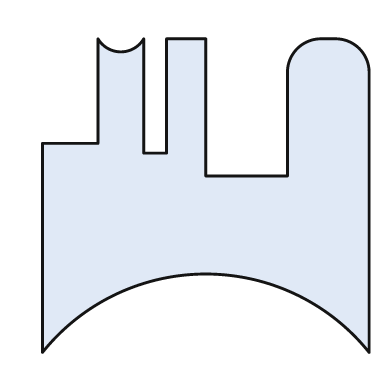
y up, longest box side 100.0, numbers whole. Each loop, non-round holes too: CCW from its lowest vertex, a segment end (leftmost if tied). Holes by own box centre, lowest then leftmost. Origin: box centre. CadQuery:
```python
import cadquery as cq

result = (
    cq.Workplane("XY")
    .moveTo(-50.0, -48.0)
    .threePointArc((0.0, -24.0), (50.0, -48.0))
    .lineTo(50.0, 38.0)
    .threePointArc((47.0, 45.0), (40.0, 48.0))
    .lineTo(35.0, 48.0)
    .threePointArc((28.0, 45.0), (25.0, 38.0))
    .lineTo(25.0, 6.0)
    .lineTo(0.0, 6.0)
    .lineTo(0.0, 48.0)
    .lineTo(-12.0, 48.0)
    .lineTo(-12.0, 13.0)
    .lineTo(-19.0, 13.0)
    .lineTo(-19.0, 48.0)
    .threePointArc((-26.0, 44.0), (-33.0, 48.0))
    .lineTo(-33.0, 16.0)
    .lineTo(-50.0, 16.0)
    .close()
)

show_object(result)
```